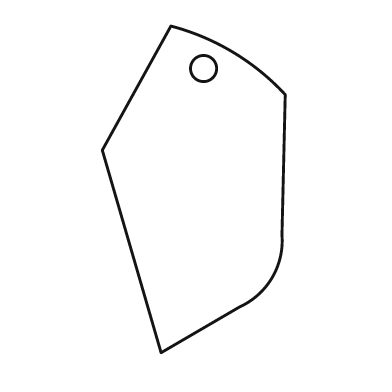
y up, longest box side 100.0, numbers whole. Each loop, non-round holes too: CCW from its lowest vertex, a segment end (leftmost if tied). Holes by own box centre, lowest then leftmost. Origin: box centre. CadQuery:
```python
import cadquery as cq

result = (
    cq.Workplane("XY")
    .moveTo(-10.0, -50.0)
    .lineTo(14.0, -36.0)
    .threePointArc((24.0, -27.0), (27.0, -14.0))
    .lineTo(28.0, 29.0)
    .threePointArc((12.0, 42.0), (-7.0, 50.0))
    .lineTo(-28.0, 12.0)
    .close()
    .moveTo(3.0, 37.0)
    .circle(4.0)
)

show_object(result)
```